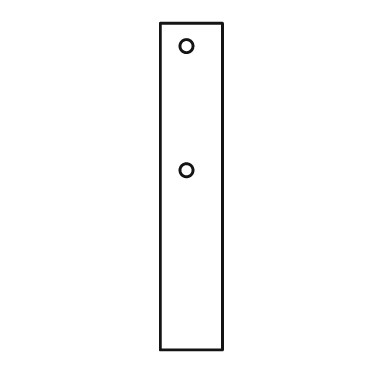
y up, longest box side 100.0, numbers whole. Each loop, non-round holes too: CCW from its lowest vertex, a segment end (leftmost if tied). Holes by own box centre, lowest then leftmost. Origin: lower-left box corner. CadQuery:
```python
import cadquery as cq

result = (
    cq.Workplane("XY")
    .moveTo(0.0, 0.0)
    .lineTo(19.0, 0.0)
    .lineTo(19.0, 100.0)
    .lineTo(0.0, 100.0)
    .close()
    .moveTo(8.0, 55.0)
    .circle(2.0)
    .moveTo(8.0, 93.0)
    .circle(2.0)
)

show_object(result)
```